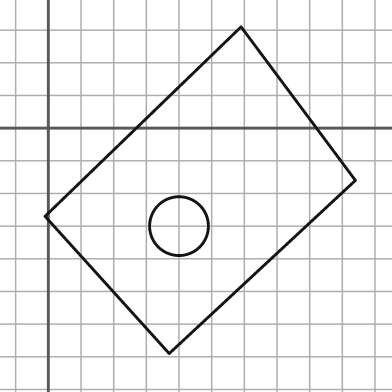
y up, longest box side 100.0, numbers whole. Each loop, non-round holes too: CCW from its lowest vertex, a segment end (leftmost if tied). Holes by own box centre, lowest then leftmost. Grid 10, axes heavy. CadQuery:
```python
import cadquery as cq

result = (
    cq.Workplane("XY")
    .moveTo(37.0, -69.0)
    .lineTo(94.0, -16.0)
    .lineTo(59.0, 31.0)
    .lineTo(-1.0, -27.0)
    .close()
    .moveTo(40.0, -30.0)
    .circle(9.0)
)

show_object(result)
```